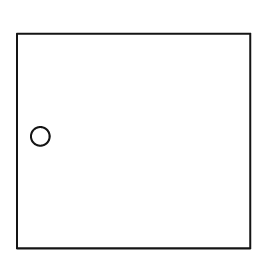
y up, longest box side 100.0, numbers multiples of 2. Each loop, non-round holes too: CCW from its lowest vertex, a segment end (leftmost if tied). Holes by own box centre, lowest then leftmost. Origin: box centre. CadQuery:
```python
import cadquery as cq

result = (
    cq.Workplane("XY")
    .moveTo(-50.0, -46.0)
    .lineTo(50.0, -46.0)
    .lineTo(50.0, 46.0)
    .lineTo(-50.0, 46.0)
    .close()
    .moveTo(-40.0, 2.0)
    .circle(4.0)
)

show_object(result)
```